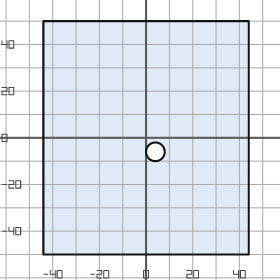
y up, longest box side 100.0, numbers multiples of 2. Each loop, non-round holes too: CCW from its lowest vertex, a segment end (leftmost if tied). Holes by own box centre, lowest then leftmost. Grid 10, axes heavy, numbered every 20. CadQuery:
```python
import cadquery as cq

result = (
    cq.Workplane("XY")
    .moveTo(-44.0, -50.0)
    .lineTo(44.0, -50.0)
    .lineTo(44.0, 50.0)
    .lineTo(-44.0, 50.0)
    .close()
    .moveTo(4.0, -6.0)
    .circle(4.0)
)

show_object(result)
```